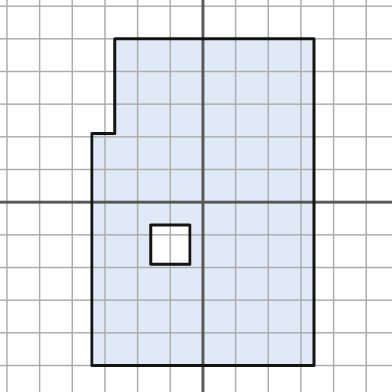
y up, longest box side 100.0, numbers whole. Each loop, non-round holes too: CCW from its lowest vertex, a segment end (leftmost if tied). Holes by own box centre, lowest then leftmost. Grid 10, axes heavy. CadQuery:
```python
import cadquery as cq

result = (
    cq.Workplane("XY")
    .moveTo(-34.0, -50.0)
    .lineTo(34.0, -50.0)
    .lineTo(34.0, 50.0)
    .lineTo(-27.0, 50.0)
    .lineTo(-27.0, 21.0)
    .lineTo(-34.0, 21.0)
    .close()
    .moveTo(-16.0, -19.0)
    .lineTo(-4.0, -19.0)
    .lineTo(-4.0, -7.0)
    .lineTo(-16.0, -7.0)
    .close()
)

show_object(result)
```